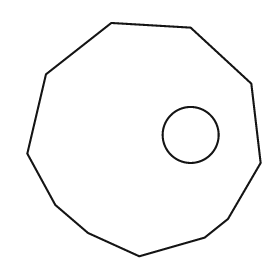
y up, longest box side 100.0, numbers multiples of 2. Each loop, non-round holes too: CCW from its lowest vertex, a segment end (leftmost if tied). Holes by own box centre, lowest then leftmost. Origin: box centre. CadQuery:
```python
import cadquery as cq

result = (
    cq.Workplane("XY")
    .moveTo(-2.0, -50.0)
    .lineTo(26.0, -42.0)
    .lineTo(36.0, -34.0)
    .lineTo(50.0, -10.0)
    .lineTo(46.0, 24.0)
    .lineTo(20.0, 48.0)
    .lineTo(-14.0, 50.0)
    .lineTo(-42.0, 28.0)
    .lineTo(-50.0, -6.0)
    .lineTo(-38.0, -28.0)
    .lineTo(-24.0, -40.0)
    .close()
    .moveTo(20.0, 2.0)
    .circle(12.0)
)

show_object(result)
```